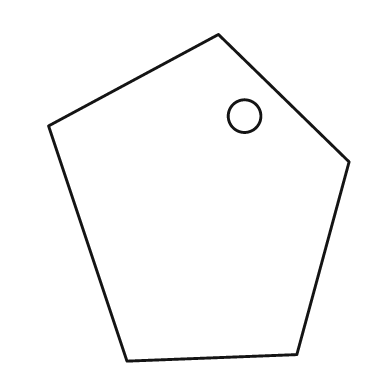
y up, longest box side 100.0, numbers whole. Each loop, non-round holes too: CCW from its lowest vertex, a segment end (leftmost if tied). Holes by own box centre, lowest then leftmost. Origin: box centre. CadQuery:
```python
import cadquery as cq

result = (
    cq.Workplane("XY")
    .moveTo(-22.0, -50.0)
    .lineTo(30.0, -48.0)
    .lineTo(46.0, 11.0)
    .lineTo(6.0, 50.0)
    .lineTo(-46.0, 22.0)
    .close()
    .moveTo(14.0, 25.0)
    .circle(5.0)
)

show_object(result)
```